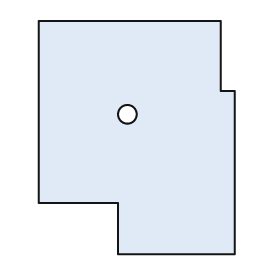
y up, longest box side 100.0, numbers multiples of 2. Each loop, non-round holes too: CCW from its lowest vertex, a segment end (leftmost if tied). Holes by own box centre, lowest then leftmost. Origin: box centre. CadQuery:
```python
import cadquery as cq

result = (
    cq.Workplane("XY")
    .moveTo(-8.0, -50.0)
    .lineTo(42.0, -50.0)
    .lineTo(42.0, 20.0)
    .lineTo(36.0, 20.0)
    .lineTo(36.0, 50.0)
    .lineTo(-42.0, 50.0)
    .lineTo(-42.0, -28.0)
    .lineTo(-8.0, -28.0)
    .close()
    .moveTo(-4.0, 10.0)
    .circle(4.0)
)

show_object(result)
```